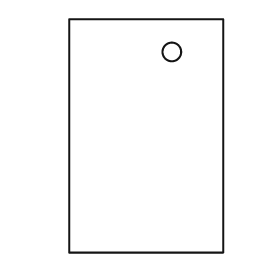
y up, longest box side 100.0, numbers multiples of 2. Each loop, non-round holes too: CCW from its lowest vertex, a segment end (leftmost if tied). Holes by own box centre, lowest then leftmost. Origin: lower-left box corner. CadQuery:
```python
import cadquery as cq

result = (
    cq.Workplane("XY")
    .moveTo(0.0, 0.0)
    .lineTo(66.0, 0.0)
    .lineTo(66.0, 100.0)
    .lineTo(0.0, 100.0)
    .close()
    .moveTo(44.0, 86.0)
    .circle(4.0)
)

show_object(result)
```